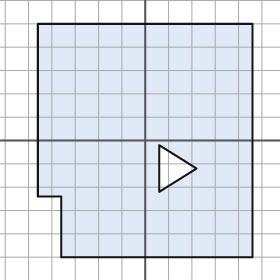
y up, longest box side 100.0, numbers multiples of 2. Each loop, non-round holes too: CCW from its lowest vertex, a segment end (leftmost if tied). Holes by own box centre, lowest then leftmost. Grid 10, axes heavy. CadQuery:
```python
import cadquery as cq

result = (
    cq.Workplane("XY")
    .moveTo(-36.0, -50.0)
    .lineTo(46.0, -50.0)
    .lineTo(46.0, 50.0)
    .lineTo(-46.0, 50.0)
    .lineTo(-46.0, -24.0)
    .lineTo(-36.0, -24.0)
    .close()
    .moveTo(6.0, -22.0)
    .lineTo(22.0, -12.0)
    .lineTo(6.0, -2.0)
    .close()
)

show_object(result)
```